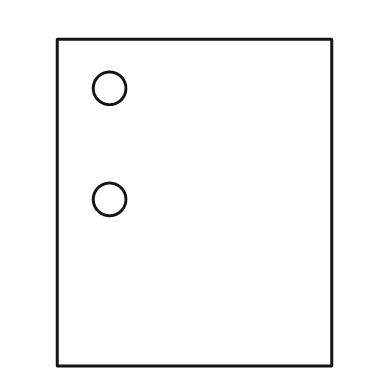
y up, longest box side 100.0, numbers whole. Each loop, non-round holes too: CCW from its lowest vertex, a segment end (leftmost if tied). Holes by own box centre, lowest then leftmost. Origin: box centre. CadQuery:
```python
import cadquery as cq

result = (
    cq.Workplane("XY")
    .moveTo(-42.0, -50.0)
    .lineTo(42.0, -50.0)
    .lineTo(42.0, 50.0)
    .lineTo(-42.0, 50.0)
    .close()
    .moveTo(-26.0, 1.0)
    .circle(5.0)
    .moveTo(-26.0, 35.0)
    .circle(5.0)
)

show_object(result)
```